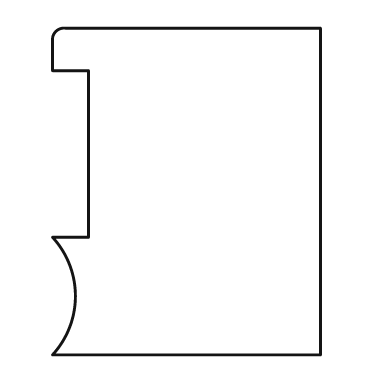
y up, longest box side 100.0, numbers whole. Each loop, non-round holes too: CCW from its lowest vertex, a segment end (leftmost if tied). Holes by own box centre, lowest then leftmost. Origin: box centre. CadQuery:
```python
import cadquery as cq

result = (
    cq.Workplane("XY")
    .moveTo(-41.0, -50.0)
    .lineTo(41.0, -50.0)
    .lineTo(41.0, 50.0)
    .lineTo(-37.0, 50.0)
    .threePointArc((-40.0, 49.0), (-41.0, 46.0))
    .lineTo(-41.0, 37.0)
    .lineTo(-30.0, 37.0)
    .lineTo(-30.0, -14.0)
    .lineTo(-41.0, -14.0)
    .threePointArc((-34.0, -32.0), (-41.0, -50.0))
    .close()
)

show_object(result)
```